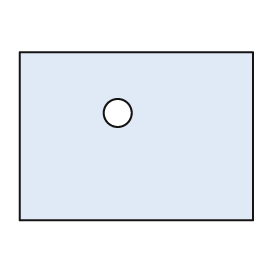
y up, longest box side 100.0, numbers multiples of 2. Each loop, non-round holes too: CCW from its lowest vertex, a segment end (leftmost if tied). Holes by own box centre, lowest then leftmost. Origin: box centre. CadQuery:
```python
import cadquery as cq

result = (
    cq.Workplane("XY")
    .moveTo(-50.0, -36.0)
    .lineTo(50.0, -36.0)
    .lineTo(50.0, 36.0)
    .lineTo(-50.0, 36.0)
    .close()
    .moveTo(-8.0, 10.0)
    .circle(6.0)
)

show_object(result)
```